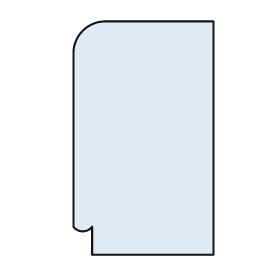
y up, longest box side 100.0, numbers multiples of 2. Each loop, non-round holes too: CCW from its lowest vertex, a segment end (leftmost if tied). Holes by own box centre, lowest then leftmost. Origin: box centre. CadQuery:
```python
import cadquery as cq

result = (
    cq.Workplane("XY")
    .moveTo(-22.0, -50.0)
    .lineTo(30.0, -50.0)
    .lineTo(30.0, 50.0)
    .lineTo(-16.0, 50.0)
    .threePointArc((-26.0, 46.0), (-30.0, 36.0))
    .lineTo(-30.0, -38.0)
    .threePointArc((-26.0, -40.0), (-22.0, -38.0))
    .close()
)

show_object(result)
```